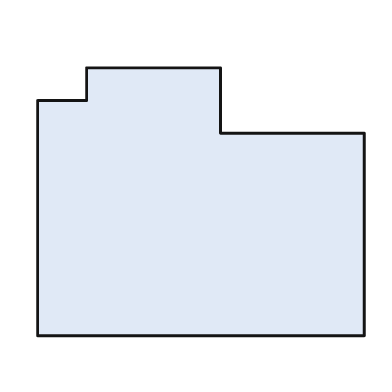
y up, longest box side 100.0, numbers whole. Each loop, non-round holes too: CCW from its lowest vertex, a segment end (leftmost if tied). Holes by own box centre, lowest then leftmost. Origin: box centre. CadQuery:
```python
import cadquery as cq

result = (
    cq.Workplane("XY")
    .moveTo(-50.0, -41.0)
    .lineTo(50.0, -41.0)
    .lineTo(50.0, 21.0)
    .lineTo(6.0, 21.0)
    .lineTo(6.0, 41.0)
    .lineTo(-35.0, 41.0)
    .lineTo(-35.0, 31.0)
    .lineTo(-50.0, 31.0)
    .close()
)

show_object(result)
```